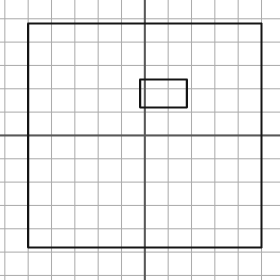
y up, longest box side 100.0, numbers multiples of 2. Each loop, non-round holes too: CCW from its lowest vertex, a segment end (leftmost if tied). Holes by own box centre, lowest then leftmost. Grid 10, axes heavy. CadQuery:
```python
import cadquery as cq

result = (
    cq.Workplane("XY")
    .moveTo(-50.0, -48.0)
    .lineTo(50.0, -48.0)
    .lineTo(50.0, 48.0)
    .lineTo(-50.0, 48.0)
    .close()
    .moveTo(-2.0, 12.0)
    .lineTo(18.0, 12.0)
    .lineTo(18.0, 24.0)
    .lineTo(-2.0, 24.0)
    .close()
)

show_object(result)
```